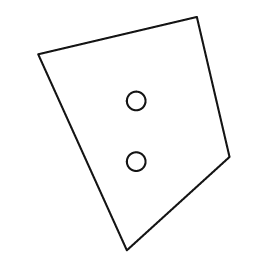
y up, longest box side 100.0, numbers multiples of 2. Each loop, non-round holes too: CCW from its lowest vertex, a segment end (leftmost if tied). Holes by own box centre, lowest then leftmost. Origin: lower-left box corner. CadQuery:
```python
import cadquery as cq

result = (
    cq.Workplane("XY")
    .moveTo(38.0, 0.0)
    .lineTo(82.0, 40.0)
    .lineTo(68.0, 100.0)
    .lineTo(0.0, 84.0)
    .close()
    .moveTo(42.0, 38.0)
    .circle(4.0)
    .moveTo(42.0, 64.0)
    .circle(4.0)
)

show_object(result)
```